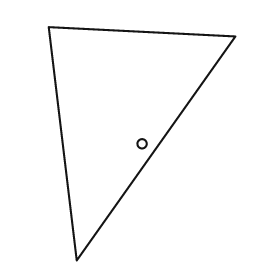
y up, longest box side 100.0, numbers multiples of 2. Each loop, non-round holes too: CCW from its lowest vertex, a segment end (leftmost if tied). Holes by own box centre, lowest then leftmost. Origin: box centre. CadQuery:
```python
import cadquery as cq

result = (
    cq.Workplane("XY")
    .moveTo(-28.0, -50.0)
    .lineTo(40.0, 46.0)
    .lineTo(-40.0, 50.0)
    .close()
    .moveTo(0.0, 0.0)
    .circle(2.0)
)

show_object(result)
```